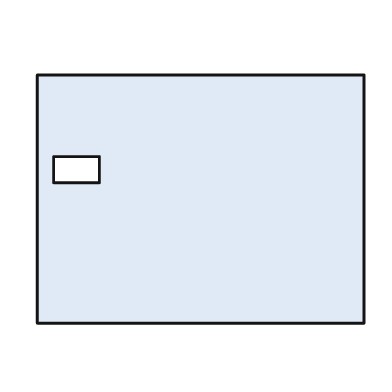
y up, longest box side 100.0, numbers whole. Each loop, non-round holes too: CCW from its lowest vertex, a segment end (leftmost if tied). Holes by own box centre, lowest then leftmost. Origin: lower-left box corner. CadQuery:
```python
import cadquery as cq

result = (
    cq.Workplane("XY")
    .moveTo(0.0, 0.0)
    .lineTo(100.0, 0.0)
    .lineTo(100.0, 76.0)
    .lineTo(0.0, 76.0)
    .close()
    .moveTo(5.0, 43.0)
    .lineTo(19.0, 43.0)
    .lineTo(19.0, 51.0)
    .lineTo(5.0, 51.0)
    .close()
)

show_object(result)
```